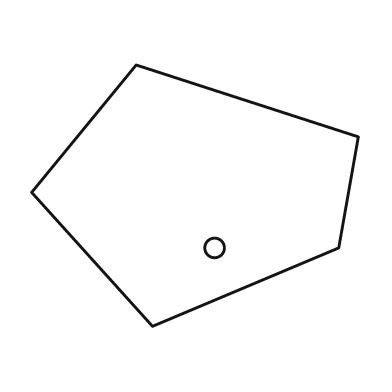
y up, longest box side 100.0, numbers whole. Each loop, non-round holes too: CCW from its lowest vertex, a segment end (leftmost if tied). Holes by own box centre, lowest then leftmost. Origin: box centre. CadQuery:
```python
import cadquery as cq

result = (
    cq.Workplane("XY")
    .moveTo(-13.0, -40.0)
    .lineTo(44.0, -16.0)
    .lineTo(50.0, 18.0)
    .lineTo(-18.0, 40.0)
    .lineTo(-50.0, 1.0)
    .close()
    .moveTo(6.0, -16.0)
    .circle(3.0)
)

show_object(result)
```